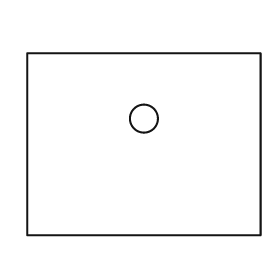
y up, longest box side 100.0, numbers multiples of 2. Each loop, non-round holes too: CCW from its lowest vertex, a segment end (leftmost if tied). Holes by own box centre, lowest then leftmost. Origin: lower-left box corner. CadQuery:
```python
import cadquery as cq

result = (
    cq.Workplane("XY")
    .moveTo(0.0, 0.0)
    .lineTo(100.0, 0.0)
    .lineTo(100.0, 78.0)
    .lineTo(0.0, 78.0)
    .close()
    .moveTo(50.0, 50.0)
    .circle(6.0)
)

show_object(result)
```